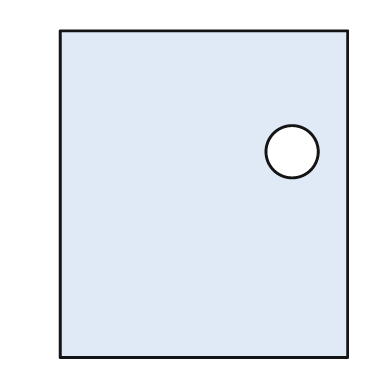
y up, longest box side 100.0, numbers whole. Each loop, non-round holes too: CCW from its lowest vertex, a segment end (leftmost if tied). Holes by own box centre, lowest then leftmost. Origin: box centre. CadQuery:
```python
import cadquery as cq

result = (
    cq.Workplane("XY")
    .moveTo(-44.0, -50.0)
    .lineTo(44.0, -50.0)
    .lineTo(44.0, 50.0)
    .lineTo(-44.0, 50.0)
    .close()
    .moveTo(27.0, 13.0)
    .circle(8.0)
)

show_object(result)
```